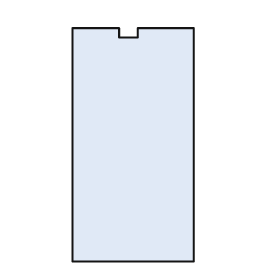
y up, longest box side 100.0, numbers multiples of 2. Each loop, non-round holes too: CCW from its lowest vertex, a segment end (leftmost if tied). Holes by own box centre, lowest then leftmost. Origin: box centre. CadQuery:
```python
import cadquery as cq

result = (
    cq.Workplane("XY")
    .moveTo(-26.0, -50.0)
    .lineTo(26.0, -50.0)
    .lineTo(26.0, 50.0)
    .lineTo(2.0, 50.0)
    .lineTo(2.0, 46.0)
    .lineTo(-6.0, 46.0)
    .lineTo(-6.0, 50.0)
    .lineTo(-26.0, 50.0)
    .close()
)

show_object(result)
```